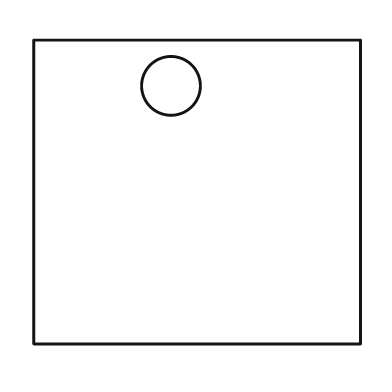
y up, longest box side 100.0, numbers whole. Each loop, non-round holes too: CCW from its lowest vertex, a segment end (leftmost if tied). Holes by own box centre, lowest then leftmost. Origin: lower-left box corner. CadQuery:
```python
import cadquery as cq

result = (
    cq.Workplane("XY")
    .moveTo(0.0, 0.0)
    .lineTo(100.0, 0.0)
    .lineTo(100.0, 93.0)
    .lineTo(0.0, 93.0)
    .close()
    .moveTo(42.0, 79.0)
    .circle(9.0)
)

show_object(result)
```